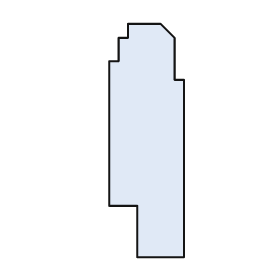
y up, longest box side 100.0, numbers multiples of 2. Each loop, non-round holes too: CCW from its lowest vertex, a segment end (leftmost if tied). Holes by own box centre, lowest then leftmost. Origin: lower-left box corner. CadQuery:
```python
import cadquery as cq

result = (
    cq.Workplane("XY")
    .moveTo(12.0, 0.0)
    .lineTo(32.0, 0.0)
    .lineTo(32.0, 76.0)
    .lineTo(28.0, 76.0)
    .lineTo(28.0, 94.0)
    .lineTo(22.0, 100.0)
    .lineTo(8.0, 100.0)
    .lineTo(8.0, 94.0)
    .lineTo(4.0, 94.0)
    .lineTo(4.0, 84.0)
    .lineTo(0.0, 84.0)
    .lineTo(0.0, 22.0)
    .lineTo(12.0, 22.0)
    .close()
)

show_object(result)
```